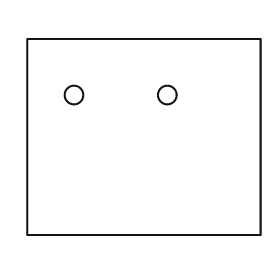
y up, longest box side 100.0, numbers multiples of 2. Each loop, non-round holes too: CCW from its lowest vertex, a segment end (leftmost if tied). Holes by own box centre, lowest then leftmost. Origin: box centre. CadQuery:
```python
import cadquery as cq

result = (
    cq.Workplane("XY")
    .moveTo(-50.0, -42.0)
    .lineTo(50.0, -42.0)
    .lineTo(50.0, 42.0)
    .lineTo(-50.0, 42.0)
    .close()
    .moveTo(-30.0, 18.0)
    .circle(4.0)
    .moveTo(10.0, 18.0)
    .circle(4.0)
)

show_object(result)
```